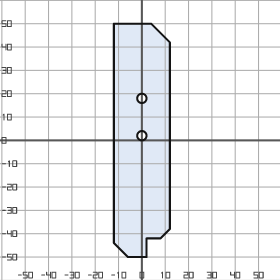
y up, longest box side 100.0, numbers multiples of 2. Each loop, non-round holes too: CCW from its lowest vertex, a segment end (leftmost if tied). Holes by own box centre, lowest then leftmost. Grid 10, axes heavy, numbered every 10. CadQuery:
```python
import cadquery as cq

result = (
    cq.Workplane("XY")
    .moveTo(-6.0, -50.0)
    .lineTo(2.0, -50.0)
    .lineTo(2.0, -42.0)
    .lineTo(8.0, -42.0)
    .lineTo(12.0, -38.0)
    .lineTo(12.0, 42.0)
    .lineTo(4.0, 50.0)
    .lineTo(-12.0, 50.0)
    .lineTo(-12.0, -44.0)
    .close()
    .moveTo(0.0, 2.0)
    .circle(2.0)
    .moveTo(0.0, 18.0)
    .circle(2.0)
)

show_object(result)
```